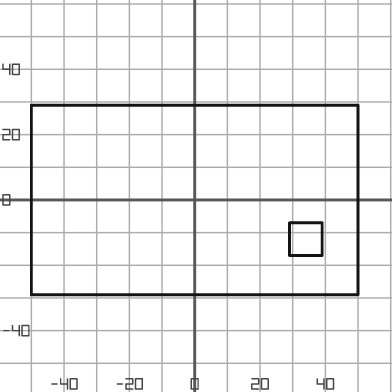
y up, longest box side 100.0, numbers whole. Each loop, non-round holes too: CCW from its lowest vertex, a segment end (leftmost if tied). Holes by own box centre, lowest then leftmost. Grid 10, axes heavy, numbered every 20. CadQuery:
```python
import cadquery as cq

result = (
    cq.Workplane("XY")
    .moveTo(-50.0, -29.0)
    .lineTo(50.0, -29.0)
    .lineTo(50.0, 29.0)
    .lineTo(-50.0, 29.0)
    .close()
    .moveTo(29.0, -17.0)
    .lineTo(39.0, -17.0)
    .lineTo(39.0, -7.0)
    .lineTo(29.0, -7.0)
    .close()
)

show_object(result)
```